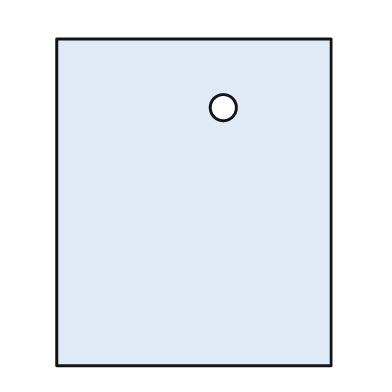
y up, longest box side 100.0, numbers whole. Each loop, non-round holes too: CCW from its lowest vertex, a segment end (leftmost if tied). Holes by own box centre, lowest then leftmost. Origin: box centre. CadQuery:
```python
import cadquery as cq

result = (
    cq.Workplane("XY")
    .moveTo(-42.0, -50.0)
    .lineTo(42.0, -50.0)
    .lineTo(42.0, 50.0)
    .lineTo(-42.0, 50.0)
    .close()
    .moveTo(9.0, 29.0)
    .circle(4.0)
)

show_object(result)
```